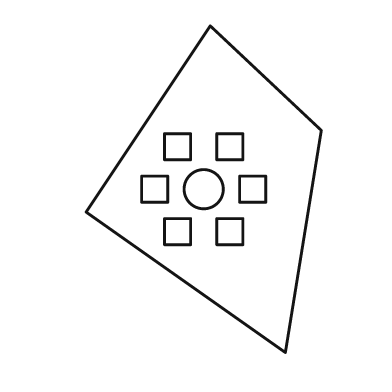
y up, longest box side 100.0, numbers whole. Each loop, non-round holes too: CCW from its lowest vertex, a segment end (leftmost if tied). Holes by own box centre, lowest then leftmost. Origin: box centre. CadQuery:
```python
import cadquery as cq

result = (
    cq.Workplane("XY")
    .moveTo(25.0, -50.0)
    .lineTo(36.0, 18.0)
    .lineTo(2.0, 50.0)
    .lineTo(-36.0, -7.0)
    .close()
    .moveTo(-12.0, -17.0)
    .lineTo(-4.0, -17.0)
    .lineTo(-4.0, -9.0)
    .lineTo(-12.0, -9.0)
    .close()
    .moveTo(4.0, -17.0)
    .lineTo(12.0, -17.0)
    .lineTo(12.0, -9.0)
    .lineTo(4.0, -9.0)
    .close()
    .moveTo(-19.0, -4.0)
    .lineTo(-11.0, -4.0)
    .lineTo(-11.0, 4.0)
    .lineTo(-19.0, 4.0)
    .close()
    .moveTo(0.0, 0.0)
    .circle(6.0)
    .moveTo(11.0, -4.0)
    .lineTo(19.0, -4.0)
    .lineTo(19.0, 4.0)
    .lineTo(11.0, 4.0)
    .close()
    .moveTo(-12.0, 9.0)
    .lineTo(-4.0, 9.0)
    .lineTo(-4.0, 17.0)
    .lineTo(-12.0, 17.0)
    .close()
    .moveTo(4.0, 9.0)
    .lineTo(12.0, 9.0)
    .lineTo(12.0, 17.0)
    .lineTo(4.0, 17.0)
    .close()
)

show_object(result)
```